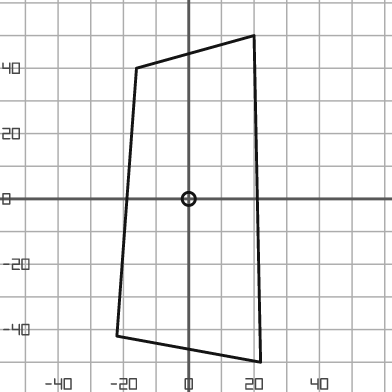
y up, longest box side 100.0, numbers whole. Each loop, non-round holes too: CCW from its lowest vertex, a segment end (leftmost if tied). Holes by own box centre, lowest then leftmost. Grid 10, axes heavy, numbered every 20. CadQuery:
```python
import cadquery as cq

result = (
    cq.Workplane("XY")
    .moveTo(22.0, -50.0)
    .lineTo(20.0, 50.0)
    .lineTo(-16.0, 40.0)
    .lineTo(-22.0, -42.0)
    .close()
    .moveTo(0.0, 0.0)
    .circle(2.0)
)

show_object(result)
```